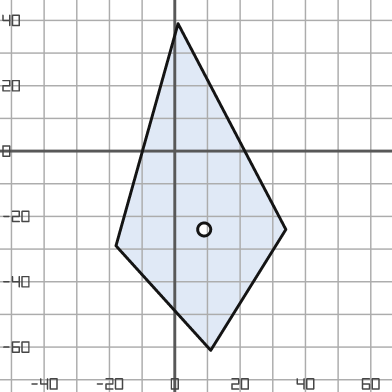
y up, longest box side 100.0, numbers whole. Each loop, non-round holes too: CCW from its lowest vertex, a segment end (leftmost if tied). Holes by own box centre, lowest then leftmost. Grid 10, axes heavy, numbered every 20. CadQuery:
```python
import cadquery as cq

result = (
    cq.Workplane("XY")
    .moveTo(11.0, -61.0)
    .lineTo(34.0, -24.0)
    .lineTo(1.0, 39.0)
    .lineTo(-18.0, -29.0)
    .close()
    .moveTo(9.0, -24.0)
    .circle(2.0)
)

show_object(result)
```